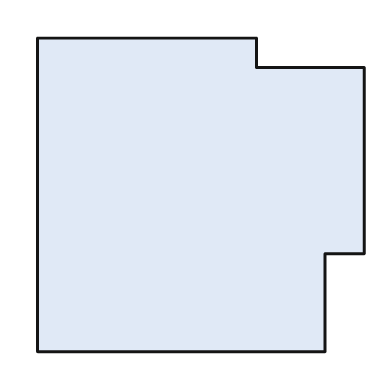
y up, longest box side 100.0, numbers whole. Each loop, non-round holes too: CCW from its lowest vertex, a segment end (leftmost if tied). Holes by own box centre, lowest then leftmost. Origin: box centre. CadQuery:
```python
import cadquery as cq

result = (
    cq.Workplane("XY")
    .moveTo(-50.0, -48.0)
    .lineTo(38.0, -48.0)
    .lineTo(38.0, -18.0)
    .lineTo(50.0, -18.0)
    .lineTo(50.0, 39.0)
    .lineTo(17.0, 39.0)
    .lineTo(17.0, 48.0)
    .lineTo(-50.0, 48.0)
    .close()
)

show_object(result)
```